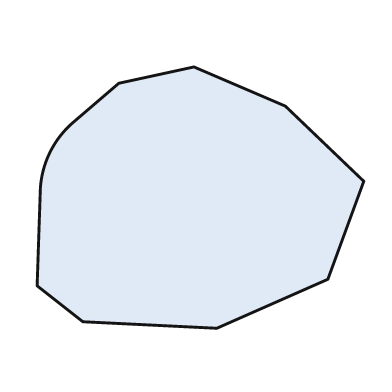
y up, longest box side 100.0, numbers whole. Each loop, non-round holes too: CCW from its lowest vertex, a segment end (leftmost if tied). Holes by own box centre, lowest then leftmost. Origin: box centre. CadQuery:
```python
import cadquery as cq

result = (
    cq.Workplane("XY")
    .moveTo(5.0, -40.0)
    .lineTo(39.0, -25.0)
    .lineTo(50.0, 5.0)
    .lineTo(26.0, 28.0)
    .lineTo(-2.0, 40.0)
    .lineTo(-25.0, 35.0)
    .lineTo(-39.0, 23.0)
    .threePointArc((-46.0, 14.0), (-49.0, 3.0))
    .lineTo(-50.0, -27.0)
    .lineTo(-36.0, -38.0)
    .close()
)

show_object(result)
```